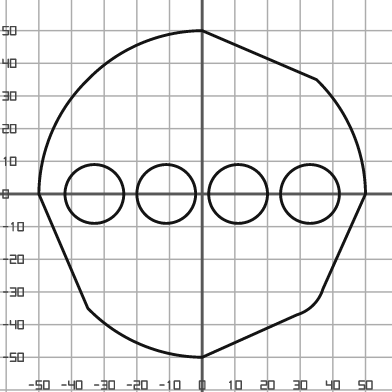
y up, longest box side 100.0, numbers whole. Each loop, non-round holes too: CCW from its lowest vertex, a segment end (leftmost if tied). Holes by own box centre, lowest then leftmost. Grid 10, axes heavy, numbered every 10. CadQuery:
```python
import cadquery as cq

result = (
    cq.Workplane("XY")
    .moveTo(0.0, -50.0)
    .lineTo(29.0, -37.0)
    .threePointArc((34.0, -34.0), (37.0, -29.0))
    .lineTo(50.0, 0.0)
    .threePointArc((46.0, 19.0), (35.0, 35.0))
    .lineTo(0.0, 50.0)
    .threePointArc((-19.0, 46.0), (-35.0, 35.0))
    .threePointArc((-46.0, 19.0), (-50.0, 0.0))
    .lineTo(-35.0, -35.0)
    .threePointArc((-19.0, -46.0), (0.0, -50.0))
    .close()
    .moveTo(-33.0, 0.0)
    .circle(9.0)
    .moveTo(-11.0, 0.0)
    .circle(9.0)
    .moveTo(11.0, 0.0)
    .circle(9.0)
    .moveTo(33.0, 0.0)
    .circle(9.0)
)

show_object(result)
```